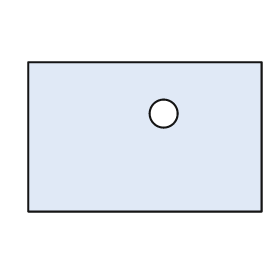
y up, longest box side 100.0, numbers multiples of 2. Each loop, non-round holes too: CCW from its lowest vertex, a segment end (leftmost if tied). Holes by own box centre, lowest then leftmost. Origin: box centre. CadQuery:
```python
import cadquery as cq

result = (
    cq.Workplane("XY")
    .moveTo(-50.0, -32.0)
    .lineTo(50.0, -32.0)
    .lineTo(50.0, 32.0)
    .lineTo(-50.0, 32.0)
    .close()
    .moveTo(8.0, 10.0)
    .circle(6.0)
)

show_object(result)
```